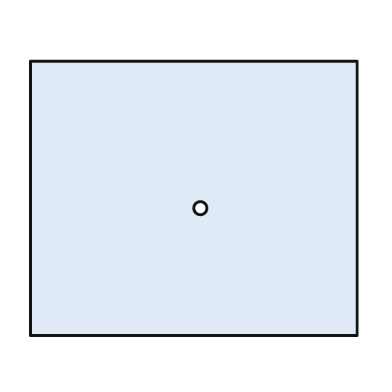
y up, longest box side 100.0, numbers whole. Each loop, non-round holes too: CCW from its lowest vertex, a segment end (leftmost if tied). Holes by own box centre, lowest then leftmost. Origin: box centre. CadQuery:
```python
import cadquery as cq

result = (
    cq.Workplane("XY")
    .moveTo(-50.0, -42.0)
    .lineTo(50.0, -42.0)
    .lineTo(50.0, 42.0)
    .lineTo(-50.0, 42.0)
    .close()
    .moveTo(2.0, -3.0)
    .circle(2.0)
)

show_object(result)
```